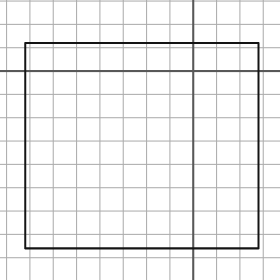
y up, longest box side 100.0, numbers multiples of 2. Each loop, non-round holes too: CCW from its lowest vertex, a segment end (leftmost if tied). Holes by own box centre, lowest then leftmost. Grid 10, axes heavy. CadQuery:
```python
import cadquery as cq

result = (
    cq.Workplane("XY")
    .moveTo(-72.0, -76.0)
    .lineTo(28.0, -76.0)
    .lineTo(28.0, 12.0)
    .lineTo(-72.0, 12.0)
    .close()
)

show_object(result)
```